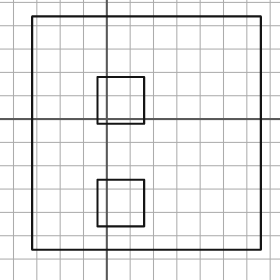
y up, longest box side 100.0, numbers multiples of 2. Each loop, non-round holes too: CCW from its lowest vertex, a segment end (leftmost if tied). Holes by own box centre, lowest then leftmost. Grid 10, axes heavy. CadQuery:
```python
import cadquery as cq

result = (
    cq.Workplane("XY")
    .moveTo(-32.0, -56.0)
    .lineTo(66.0, -56.0)
    .lineTo(66.0, 44.0)
    .lineTo(-32.0, 44.0)
    .close()
    .moveTo(-4.0, -46.0)
    .lineTo(16.0, -46.0)
    .lineTo(16.0, -26.0)
    .lineTo(-4.0, -26.0)
    .close()
    .moveTo(-4.0, -2.0)
    .lineTo(16.0, -2.0)
    .lineTo(16.0, 18.0)
    .lineTo(-4.0, 18.0)
    .close()
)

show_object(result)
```